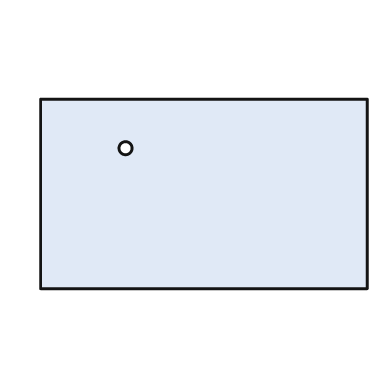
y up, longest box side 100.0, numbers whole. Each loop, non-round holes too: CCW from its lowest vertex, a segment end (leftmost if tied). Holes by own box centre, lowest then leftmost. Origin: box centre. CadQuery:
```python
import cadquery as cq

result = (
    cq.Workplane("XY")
    .moveTo(-50.0, -29.0)
    .lineTo(50.0, -29.0)
    .lineTo(50.0, 29.0)
    .lineTo(-50.0, 29.0)
    .close()
    .moveTo(-24.0, 14.0)
    .circle(2.0)
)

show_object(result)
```